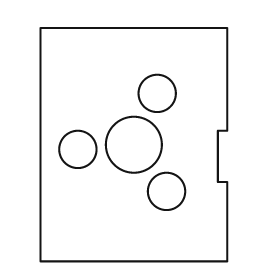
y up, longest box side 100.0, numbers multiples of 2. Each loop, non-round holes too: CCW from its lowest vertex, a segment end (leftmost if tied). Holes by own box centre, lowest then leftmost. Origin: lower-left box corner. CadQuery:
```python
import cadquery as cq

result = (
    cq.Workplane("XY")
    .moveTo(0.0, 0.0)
    .lineTo(80.0, 0.0)
    .lineTo(80.0, 34.0)
    .lineTo(76.0, 34.0)
    .lineTo(76.0, 56.0)
    .lineTo(80.0, 56.0)
    .lineTo(80.0, 100.0)
    .lineTo(0.0, 100.0)
    .close()
    .moveTo(54.0, 30.0)
    .circle(8.0)
    .moveTo(16.0, 48.0)
    .circle(8.0)
    .moveTo(40.0, 50.0)
    .circle(12.0)
    .moveTo(50.0, 72.0)
    .circle(8.0)
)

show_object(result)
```